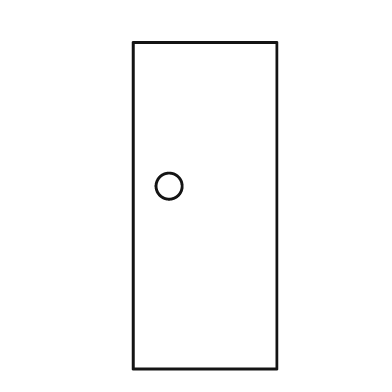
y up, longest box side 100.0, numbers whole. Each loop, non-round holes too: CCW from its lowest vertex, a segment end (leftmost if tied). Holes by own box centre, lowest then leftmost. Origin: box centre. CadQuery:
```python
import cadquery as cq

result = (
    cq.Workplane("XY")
    .moveTo(-22.0, -50.0)
    .lineTo(22.0, -50.0)
    .lineTo(22.0, 50.0)
    .lineTo(-22.0, 50.0)
    .close()
    .moveTo(-11.0, 6.0)
    .circle(4.0)
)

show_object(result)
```